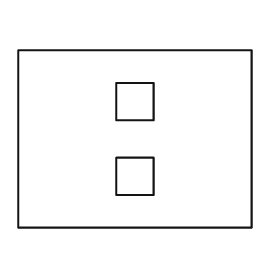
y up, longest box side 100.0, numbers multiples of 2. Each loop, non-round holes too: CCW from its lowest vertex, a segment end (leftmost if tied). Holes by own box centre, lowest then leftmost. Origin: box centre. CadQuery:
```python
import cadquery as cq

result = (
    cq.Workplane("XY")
    .moveTo(-50.0, -38.0)
    .lineTo(50.0, -38.0)
    .lineTo(50.0, 38.0)
    .lineTo(-50.0, 38.0)
    .close()
    .moveTo(-8.0, -24.0)
    .lineTo(8.0, -24.0)
    .lineTo(8.0, -8.0)
    .lineTo(-8.0, -8.0)
    .close()
    .moveTo(-8.0, 8.0)
    .lineTo(8.0, 8.0)
    .lineTo(8.0, 24.0)
    .lineTo(-8.0, 24.0)
    .close()
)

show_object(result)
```